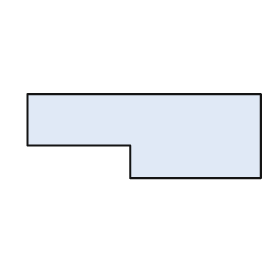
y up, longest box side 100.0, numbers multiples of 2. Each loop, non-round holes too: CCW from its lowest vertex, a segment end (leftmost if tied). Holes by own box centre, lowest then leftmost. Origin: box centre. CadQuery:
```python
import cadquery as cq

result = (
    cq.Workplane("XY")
    .moveTo(-6.0, -18.0)
    .lineTo(50.0, -18.0)
    .lineTo(50.0, 18.0)
    .lineTo(-50.0, 18.0)
    .lineTo(-50.0, -4.0)
    .lineTo(-6.0, -4.0)
    .close()
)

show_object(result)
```